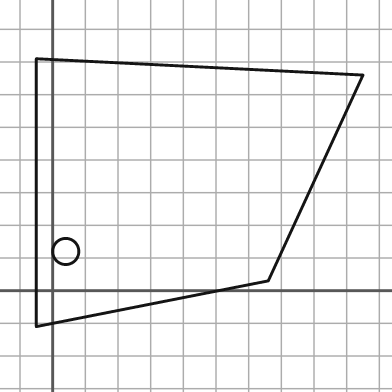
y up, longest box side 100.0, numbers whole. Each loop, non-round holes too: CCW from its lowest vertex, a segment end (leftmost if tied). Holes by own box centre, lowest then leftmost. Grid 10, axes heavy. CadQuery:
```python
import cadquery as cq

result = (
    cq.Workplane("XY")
    .moveTo(-5.0, -11.0)
    .lineTo(66.0, 3.0)
    .lineTo(95.0, 66.0)
    .lineTo(-5.0, 71.0)
    .close()
    .moveTo(4.0, 12.0)
    .circle(4.0)
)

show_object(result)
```